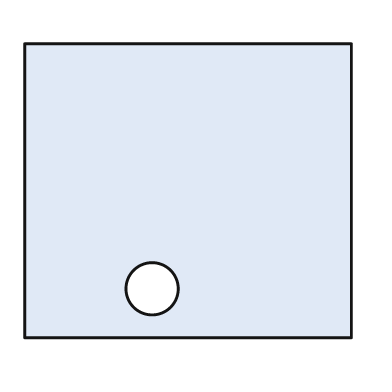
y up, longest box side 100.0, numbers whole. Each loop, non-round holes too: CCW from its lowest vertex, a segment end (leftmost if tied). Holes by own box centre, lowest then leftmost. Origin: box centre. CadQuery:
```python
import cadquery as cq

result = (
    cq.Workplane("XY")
    .moveTo(-50.0, -45.0)
    .lineTo(50.0, -45.0)
    .lineTo(50.0, 45.0)
    .lineTo(-50.0, 45.0)
    .close()
    .moveTo(-11.0, -30.0)
    .circle(8.0)
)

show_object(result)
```